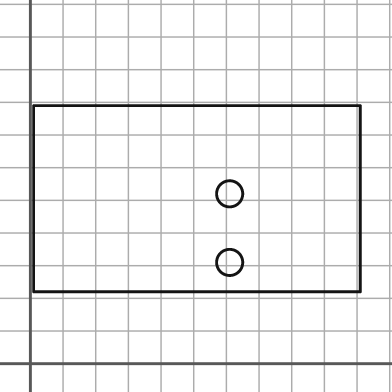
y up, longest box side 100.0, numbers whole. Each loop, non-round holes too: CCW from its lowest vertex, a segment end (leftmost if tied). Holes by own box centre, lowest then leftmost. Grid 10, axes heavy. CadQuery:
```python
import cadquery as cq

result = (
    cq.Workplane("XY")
    .moveTo(1.0, 22.0)
    .lineTo(101.0, 22.0)
    .lineTo(101.0, 79.0)
    .lineTo(1.0, 79.0)
    .close()
    .moveTo(61.0, 31.0)
    .circle(4.0)
    .moveTo(61.0, 52.0)
    .circle(4.0)
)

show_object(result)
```